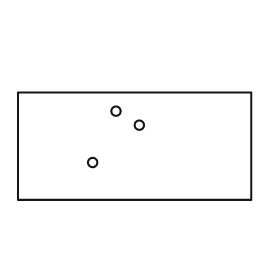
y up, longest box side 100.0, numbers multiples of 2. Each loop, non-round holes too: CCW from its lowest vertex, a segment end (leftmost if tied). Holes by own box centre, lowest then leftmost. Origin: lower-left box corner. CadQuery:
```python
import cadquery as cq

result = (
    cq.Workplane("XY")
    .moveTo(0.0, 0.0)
    .lineTo(100.0, 0.0)
    .lineTo(100.0, 46.0)
    .lineTo(0.0, 46.0)
    .close()
    .moveTo(32.0, 16.0)
    .circle(2.0)
    .moveTo(52.0, 32.0)
    .circle(2.0)
    .moveTo(42.0, 38.0)
    .circle(2.0)
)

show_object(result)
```